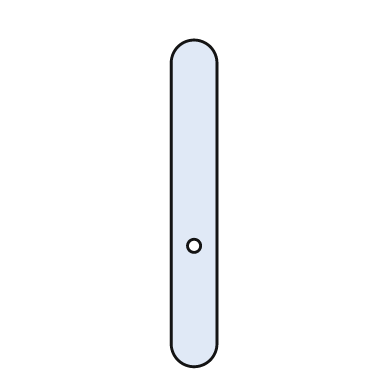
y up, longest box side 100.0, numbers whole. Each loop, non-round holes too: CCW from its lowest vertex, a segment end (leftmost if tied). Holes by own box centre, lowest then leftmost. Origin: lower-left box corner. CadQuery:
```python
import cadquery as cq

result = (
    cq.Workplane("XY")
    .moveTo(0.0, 7.0)
    .threePointArc((7.0, 0.0), (14.0, 7.0))
    .lineTo(14.0, 93.0)
    .threePointArc((7.0, 100.0), (0.0, 93.0))
    .close()
    .moveTo(7.0, 37.0)
    .circle(2.0)
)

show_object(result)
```